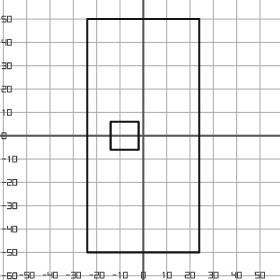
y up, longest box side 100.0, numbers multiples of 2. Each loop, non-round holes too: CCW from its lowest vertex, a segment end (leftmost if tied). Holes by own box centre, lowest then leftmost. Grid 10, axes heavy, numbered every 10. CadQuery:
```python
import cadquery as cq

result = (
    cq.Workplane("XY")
    .moveTo(-24.0, -50.0)
    .lineTo(24.0, -50.0)
    .lineTo(24.0, 50.0)
    .lineTo(-24.0, 50.0)
    .close()
    .moveTo(-14.0, -6.0)
    .lineTo(-2.0, -6.0)
    .lineTo(-2.0, 6.0)
    .lineTo(-14.0, 6.0)
    .close()
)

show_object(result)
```